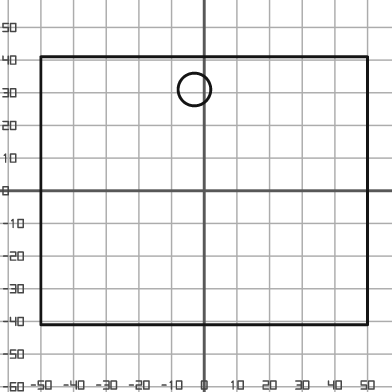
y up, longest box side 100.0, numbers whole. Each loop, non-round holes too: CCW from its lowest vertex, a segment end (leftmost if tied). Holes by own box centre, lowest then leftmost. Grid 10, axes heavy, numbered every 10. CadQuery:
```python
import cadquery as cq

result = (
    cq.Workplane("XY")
    .moveTo(-50.0, -41.0)
    .lineTo(50.0, -41.0)
    .lineTo(50.0, 41.0)
    .lineTo(-50.0, 41.0)
    .close()
    .moveTo(-3.0, 31.0)
    .circle(5.0)
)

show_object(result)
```